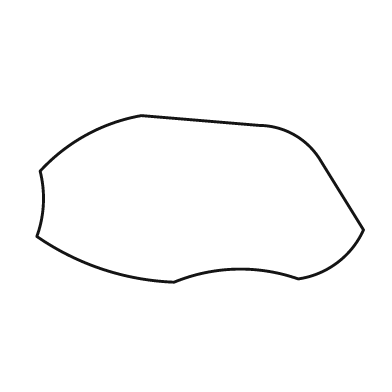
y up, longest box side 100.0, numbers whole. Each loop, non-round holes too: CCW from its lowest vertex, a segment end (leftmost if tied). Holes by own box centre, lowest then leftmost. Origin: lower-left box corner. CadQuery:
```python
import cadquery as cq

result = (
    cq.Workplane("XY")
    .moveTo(42.0, 0.0)
    .threePointArc((61.0, 4.0), (80.0, 1.0))
    .threePointArc((92.0, 6.0), (100.0, 16.0))
    .lineTo(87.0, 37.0)
    .threePointArc((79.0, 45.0), (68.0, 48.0))
    .lineTo(32.0, 51.0)
    .threePointArc((15.0, 45.0), (1.0, 34.0))
    .threePointArc((2.0, 24.0), (0.0, 14.0))
    .threePointArc((20.0, 4.0), (42.0, 0.0))
    .close()
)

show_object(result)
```